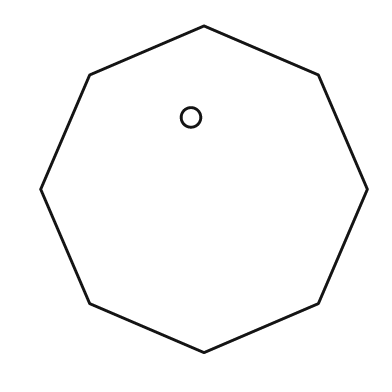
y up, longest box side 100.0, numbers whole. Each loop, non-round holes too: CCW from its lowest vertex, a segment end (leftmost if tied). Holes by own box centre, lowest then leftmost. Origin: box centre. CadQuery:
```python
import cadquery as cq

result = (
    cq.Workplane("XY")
    .moveTo(0.0, -50.0)
    .lineTo(35.0, -35.0)
    .lineTo(50.0, 0.0)
    .lineTo(35.0, 35.0)
    .lineTo(0.0, 50.0)
    .lineTo(-35.0, 35.0)
    .lineTo(-50.0, 0.0)
    .lineTo(-35.0, -35.0)
    .close()
    .moveTo(-4.0, 22.0)
    .circle(3.0)
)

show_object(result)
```